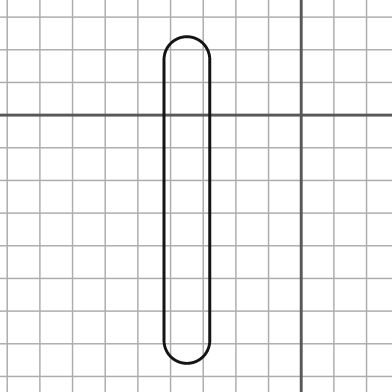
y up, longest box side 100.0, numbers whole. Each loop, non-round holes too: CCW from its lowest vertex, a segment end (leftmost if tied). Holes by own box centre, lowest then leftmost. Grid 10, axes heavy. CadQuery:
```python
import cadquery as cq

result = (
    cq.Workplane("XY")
    .moveTo(-42.0, -69.0)
    .threePointArc((-35.0, -76.0), (-28.0, -69.0))
    .lineTo(-28.0, 17.0)
    .threePointArc((-35.0, 24.0), (-42.0, 17.0))
    .close()
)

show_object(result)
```